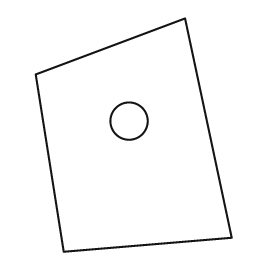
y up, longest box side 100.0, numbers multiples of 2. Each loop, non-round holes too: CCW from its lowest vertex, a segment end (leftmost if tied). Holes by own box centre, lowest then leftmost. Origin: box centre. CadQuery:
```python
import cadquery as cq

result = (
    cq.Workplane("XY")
    .moveTo(-30.0, -50.0)
    .lineTo(42.0, -44.0)
    .lineTo(22.0, 50.0)
    .lineTo(-42.0, 26.0)
    .close()
    .moveTo(-2.0, 6.0)
    .circle(8.0)
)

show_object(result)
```